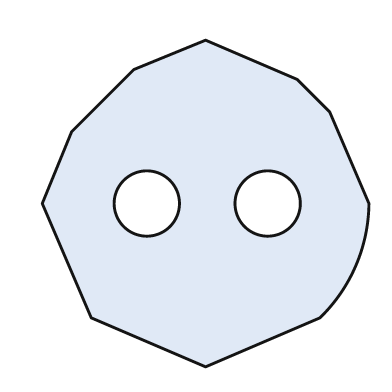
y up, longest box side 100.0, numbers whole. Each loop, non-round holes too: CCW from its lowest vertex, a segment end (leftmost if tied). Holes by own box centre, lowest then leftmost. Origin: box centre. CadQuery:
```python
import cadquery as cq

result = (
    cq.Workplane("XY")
    .moveTo(0.0, -50.0)
    .lineTo(35.0, -35.0)
    .threePointArc((46.0, -19.0), (50.0, 0.0))
    .lineTo(38.0, 28.0)
    .lineTo(28.0, 38.0)
    .lineTo(0.0, 50.0)
    .lineTo(-22.0, 41.0)
    .lineTo(-41.0, 22.0)
    .lineTo(-50.0, 0.0)
    .lineTo(-35.0, -35.0)
    .close()
    .moveTo(-18.0, 0.0)
    .circle(10.0)
    .moveTo(19.0, 0.0)
    .circle(10.0)
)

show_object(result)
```